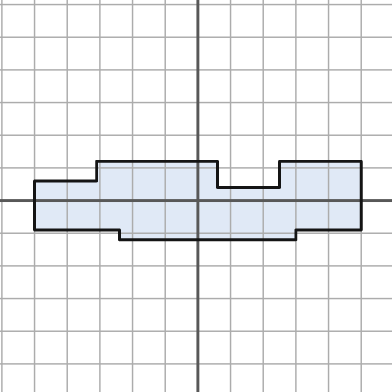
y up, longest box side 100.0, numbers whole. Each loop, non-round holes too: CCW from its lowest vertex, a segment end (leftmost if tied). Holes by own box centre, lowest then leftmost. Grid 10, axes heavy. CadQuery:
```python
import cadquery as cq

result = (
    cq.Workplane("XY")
    .moveTo(-24.0, -12.0)
    .lineTo(30.0, -12.0)
    .lineTo(30.0, -9.0)
    .lineTo(50.0, -9.0)
    .lineTo(50.0, 12.0)
    .lineTo(25.0, 12.0)
    .lineTo(25.0, 4.0)
    .lineTo(6.0, 4.0)
    .lineTo(6.0, 12.0)
    .lineTo(-31.0, 12.0)
    .lineTo(-31.0, 6.0)
    .lineTo(-50.0, 6.0)
    .lineTo(-50.0, -9.0)
    .lineTo(-24.0, -9.0)
    .close()
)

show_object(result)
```